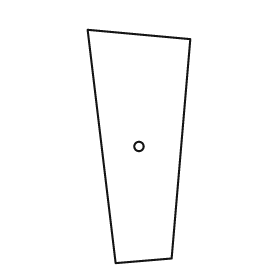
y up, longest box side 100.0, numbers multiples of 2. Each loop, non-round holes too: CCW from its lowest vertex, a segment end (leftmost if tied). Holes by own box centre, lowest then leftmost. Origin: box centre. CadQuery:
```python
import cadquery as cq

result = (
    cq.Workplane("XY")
    .moveTo(-10.0, -50.0)
    .lineTo(14.0, -48.0)
    .lineTo(22.0, 46.0)
    .lineTo(-22.0, 50.0)
    .close()
    .moveTo(0.0, 0.0)
    .circle(2.0)
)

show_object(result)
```